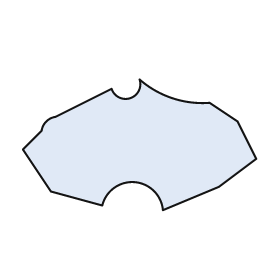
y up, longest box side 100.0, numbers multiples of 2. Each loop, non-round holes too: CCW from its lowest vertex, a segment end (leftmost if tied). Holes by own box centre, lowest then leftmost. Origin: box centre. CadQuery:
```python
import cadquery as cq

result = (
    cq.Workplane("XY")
    .moveTo(10.0, -28.0)
    .lineTo(34.0, -18.0)
    .lineTo(50.0, -6.0)
    .lineTo(42.0, 10.0)
    .lineTo(30.0, 18.0)
    .threePointArc((14.0, 20.0), (0.0, 28.0))
    .threePointArc((-4.0, 20.0), (-12.0, 24.0))
    .lineTo(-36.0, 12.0)
    .threePointArc((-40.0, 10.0), (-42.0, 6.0))
    .lineTo(-50.0, -2.0)
    .lineTo(-38.0, -20.0)
    .lineTo(-16.0, -26.0)
    .threePointArc((-2.0, -16.0), (10.0, -28.0))
    .close()
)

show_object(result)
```